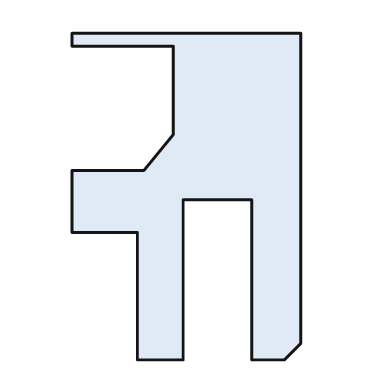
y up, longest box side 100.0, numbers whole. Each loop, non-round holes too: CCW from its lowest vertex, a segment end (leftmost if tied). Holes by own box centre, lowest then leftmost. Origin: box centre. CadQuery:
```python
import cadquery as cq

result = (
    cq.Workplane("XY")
    .moveTo(-15.0, -50.0)
    .lineTo(-1.0, -50.0)
    .lineTo(-1.0, -1.0)
    .lineTo(20.0, -1.0)
    .lineTo(20.0, -50.0)
    .lineTo(30.0, -50.0)
    .lineTo(35.0, -45.0)
    .lineTo(35.0, 50.0)
    .lineTo(-35.0, 50.0)
    .lineTo(-35.0, 46.0)
    .lineTo(-4.0, 46.0)
    .lineTo(-4.0, 19.0)
    .lineTo(-13.0, 8.0)
    .lineTo(-35.0, 8.0)
    .lineTo(-35.0, -11.0)
    .lineTo(-15.0, -11.0)
    .close()
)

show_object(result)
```